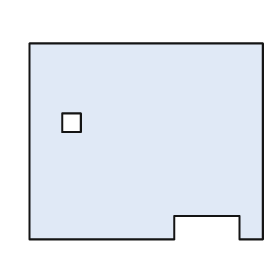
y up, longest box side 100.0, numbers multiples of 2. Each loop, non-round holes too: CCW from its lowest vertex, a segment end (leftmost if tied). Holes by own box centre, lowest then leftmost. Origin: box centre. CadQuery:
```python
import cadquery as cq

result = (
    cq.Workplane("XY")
    .moveTo(-50.0, -42.0)
    .lineTo(12.0, -42.0)
    .lineTo(12.0, -32.0)
    .lineTo(40.0, -32.0)
    .lineTo(40.0, -42.0)
    .lineTo(50.0, -42.0)
    .lineTo(50.0, 42.0)
    .lineTo(-50.0, 42.0)
    .close()
    .moveTo(-36.0, 4.0)
    .lineTo(-28.0, 4.0)
    .lineTo(-28.0, 12.0)
    .lineTo(-36.0, 12.0)
    .close()
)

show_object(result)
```